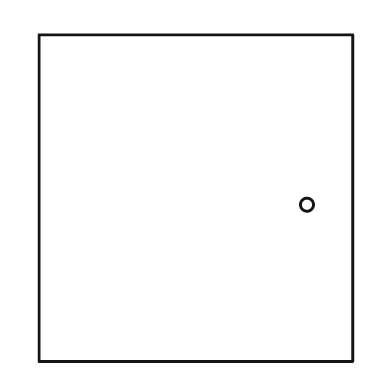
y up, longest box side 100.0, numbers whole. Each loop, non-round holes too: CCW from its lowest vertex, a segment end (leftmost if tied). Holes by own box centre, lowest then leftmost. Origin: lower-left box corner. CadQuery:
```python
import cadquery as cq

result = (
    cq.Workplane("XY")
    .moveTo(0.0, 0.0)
    .lineTo(96.0, 0.0)
    .lineTo(96.0, 100.0)
    .lineTo(0.0, 100.0)
    .close()
    .moveTo(82.0, 48.0)
    .circle(2.0)
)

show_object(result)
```